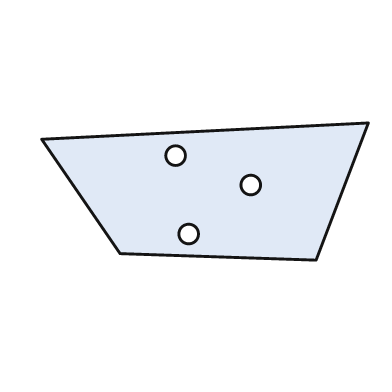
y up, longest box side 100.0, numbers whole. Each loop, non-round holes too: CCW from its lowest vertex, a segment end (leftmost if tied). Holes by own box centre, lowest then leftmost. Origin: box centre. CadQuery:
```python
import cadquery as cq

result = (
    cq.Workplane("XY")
    .moveTo(34.0, -21.0)
    .lineTo(50.0, 21.0)
    .lineTo(-50.0, 16.0)
    .lineTo(-26.0, -19.0)
    .close()
    .moveTo(-5.0, -13.0)
    .circle(3.0)
    .moveTo(14.0, 2.0)
    .circle(3.0)
    .moveTo(-9.0, 11.0)
    .circle(3.0)
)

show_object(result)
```